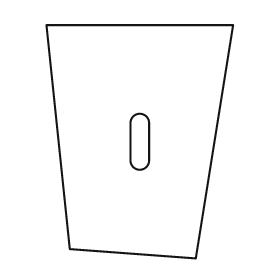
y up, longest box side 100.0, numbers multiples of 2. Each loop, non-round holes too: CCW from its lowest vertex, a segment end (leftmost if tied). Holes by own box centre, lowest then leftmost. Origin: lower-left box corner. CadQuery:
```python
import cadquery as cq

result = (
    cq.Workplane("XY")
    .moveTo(64.0, 0.0)
    .lineTo(80.0, 100.0)
    .lineTo(0.0, 100.0)
    .lineTo(10.0, 4.0)
    .close()
    .moveTo(36.0, 42.0)
    .threePointArc((40.0, 38.0), (44.0, 42.0))
    .lineTo(44.0, 58.0)
    .threePointArc((40.0, 62.0), (36.0, 58.0))
    .close()
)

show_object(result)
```